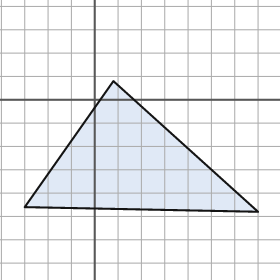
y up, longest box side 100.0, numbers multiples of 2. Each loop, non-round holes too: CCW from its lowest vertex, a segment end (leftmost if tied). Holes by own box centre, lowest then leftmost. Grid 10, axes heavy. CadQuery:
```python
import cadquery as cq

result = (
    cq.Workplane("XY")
    .moveTo(70.0, -48.0)
    .lineTo(8.0, 8.0)
    .lineTo(-30.0, -46.0)
    .close()
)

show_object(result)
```